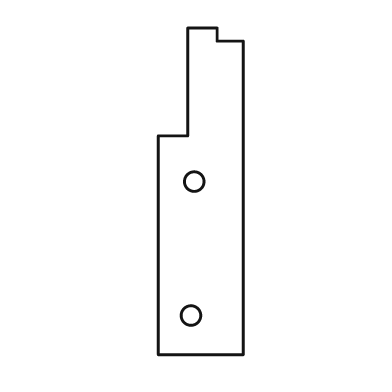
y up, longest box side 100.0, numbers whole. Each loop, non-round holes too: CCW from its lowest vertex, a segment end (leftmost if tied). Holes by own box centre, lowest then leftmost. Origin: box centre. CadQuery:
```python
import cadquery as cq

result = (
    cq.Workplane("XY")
    .moveTo(-13.0, -50.0)
    .lineTo(13.0, -50.0)
    .lineTo(13.0, 46.0)
    .lineTo(5.0, 46.0)
    .lineTo(5.0, 50.0)
    .lineTo(-4.0, 50.0)
    .lineTo(-4.0, 17.0)
    .lineTo(-13.0, 17.0)
    .close()
    .moveTo(-3.0, -38.0)
    .circle(3.0)
    .moveTo(-2.0, 3.0)
    .circle(3.0)
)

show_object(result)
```